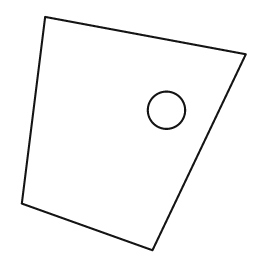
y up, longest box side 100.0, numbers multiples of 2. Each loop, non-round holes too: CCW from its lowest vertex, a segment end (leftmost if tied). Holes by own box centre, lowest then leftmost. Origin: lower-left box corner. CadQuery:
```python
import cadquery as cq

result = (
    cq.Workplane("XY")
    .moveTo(56.0, 0.0)
    .lineTo(96.0, 84.0)
    .lineTo(10.0, 100.0)
    .lineTo(0.0, 20.0)
    .close()
    .moveTo(62.0, 60.0)
    .circle(8.0)
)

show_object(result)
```